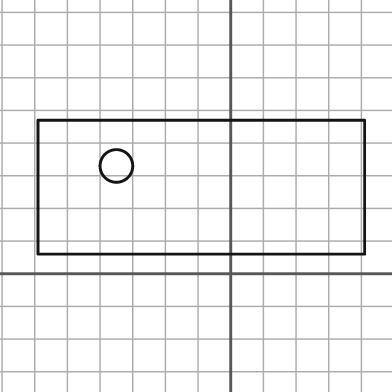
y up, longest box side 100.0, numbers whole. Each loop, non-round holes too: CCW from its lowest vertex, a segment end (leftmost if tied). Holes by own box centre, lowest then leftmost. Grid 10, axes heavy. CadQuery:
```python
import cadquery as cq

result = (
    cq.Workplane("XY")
    .moveTo(-59.0, 6.0)
    .lineTo(41.0, 6.0)
    .lineTo(41.0, 47.0)
    .lineTo(-59.0, 47.0)
    .close()
    .moveTo(-35.0, 33.0)
    .circle(5.0)
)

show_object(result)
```